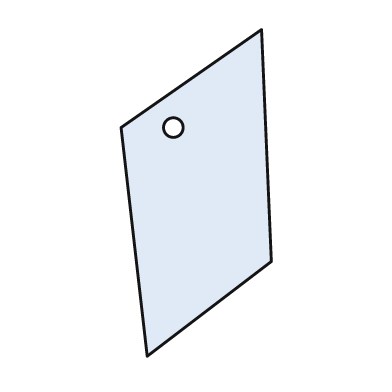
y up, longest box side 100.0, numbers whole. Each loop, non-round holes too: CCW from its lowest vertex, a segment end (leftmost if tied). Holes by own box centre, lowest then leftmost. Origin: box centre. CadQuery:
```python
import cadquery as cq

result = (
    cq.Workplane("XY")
    .moveTo(-15.0, -50.0)
    .lineTo(23.0, -21.0)
    .lineTo(20.0, 50.0)
    .lineTo(-23.0, 20.0)
    .close()
    .moveTo(-7.0, 20.0)
    .circle(3.0)
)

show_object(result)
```